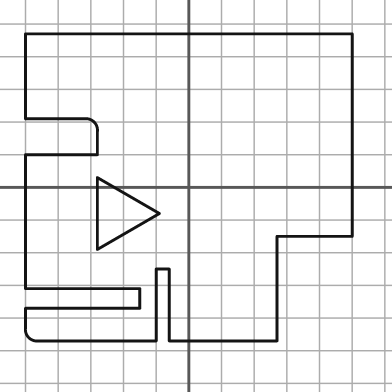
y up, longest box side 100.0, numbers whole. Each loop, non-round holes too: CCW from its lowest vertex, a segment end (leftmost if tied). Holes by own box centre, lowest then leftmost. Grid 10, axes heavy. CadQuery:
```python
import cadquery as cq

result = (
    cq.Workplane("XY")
    .moveTo(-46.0, -47.0)
    .lineTo(-10.0, -47.0)
    .lineTo(-10.0, -25.0)
    .lineTo(-6.0, -25.0)
    .lineTo(-6.0, -47.0)
    .lineTo(27.0, -47.0)
    .lineTo(27.0, -15.0)
    .lineTo(50.0, -15.0)
    .lineTo(50.0, 47.0)
    .lineTo(-50.0, 47.0)
    .lineTo(-50.0, 21.0)
    .lineTo(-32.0, 21.0)
    .threePointArc((-29.0, 20.0), (-28.0, 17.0))
    .lineTo(-28.0, 10.0)
    .lineTo(-50.0, 10.0)
    .lineTo(-50.0, -31.0)
    .lineTo(-15.0, -31.0)
    .lineTo(-15.0, -37.0)
    .lineTo(-50.0, -37.0)
    .lineTo(-50.0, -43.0)
    .threePointArc((-49.0, -46.0), (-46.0, -47.0))
    .close()
    .moveTo(-28.0, -19.0)
    .lineTo(-9.0, -8.0)
    .lineTo(-28.0, 3.0)
    .close()
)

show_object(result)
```